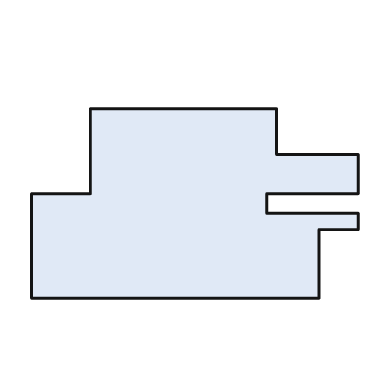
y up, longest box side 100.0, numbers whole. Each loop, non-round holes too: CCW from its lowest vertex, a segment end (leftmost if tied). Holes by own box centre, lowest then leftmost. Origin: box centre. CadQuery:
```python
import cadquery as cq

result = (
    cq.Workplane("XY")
    .moveTo(-50.0, -29.0)
    .lineTo(38.0, -29.0)
    .lineTo(38.0, -8.0)
    .lineTo(50.0, -8.0)
    .lineTo(50.0, -3.0)
    .lineTo(22.0, -3.0)
    .lineTo(22.0, 3.0)
    .lineTo(50.0, 3.0)
    .lineTo(50.0, 15.0)
    .lineTo(25.0, 15.0)
    .lineTo(25.0, 29.0)
    .lineTo(-32.0, 29.0)
    .lineTo(-32.0, 3.0)
    .lineTo(-50.0, 3.0)
    .close()
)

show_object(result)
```